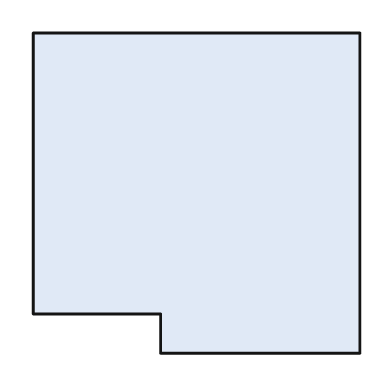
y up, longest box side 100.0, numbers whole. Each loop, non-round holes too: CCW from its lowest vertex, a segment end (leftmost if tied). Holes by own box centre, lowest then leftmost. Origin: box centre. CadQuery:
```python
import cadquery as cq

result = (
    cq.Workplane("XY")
    .moveTo(-11.0, -49.0)
    .lineTo(50.0, -49.0)
    .lineTo(50.0, 49.0)
    .lineTo(-50.0, 49.0)
    .lineTo(-50.0, -37.0)
    .lineTo(-11.0, -37.0)
    .close()
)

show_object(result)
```